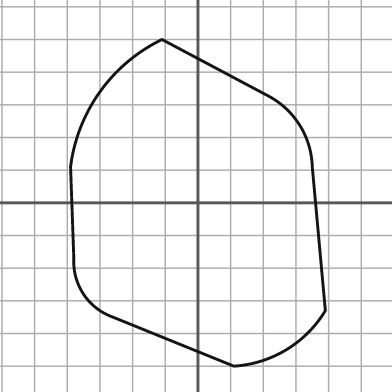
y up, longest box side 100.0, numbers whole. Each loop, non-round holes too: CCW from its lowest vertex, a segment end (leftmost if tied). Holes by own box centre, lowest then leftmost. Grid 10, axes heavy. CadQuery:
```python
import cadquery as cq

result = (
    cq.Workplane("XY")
    .moveTo(11.0, -50.0)
    .threePointArc((27.0, -45.0), (39.0, -33.0))
    .lineTo(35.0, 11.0)
    .threePointArc((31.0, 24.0), (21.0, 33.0))
    .lineTo(-11.0, 50.0)
    .threePointArc((-30.0, 34.0), (-39.0, 11.0))
    .lineTo(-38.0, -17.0)
    .threePointArc((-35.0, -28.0), (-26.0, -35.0))
    .close()
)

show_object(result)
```